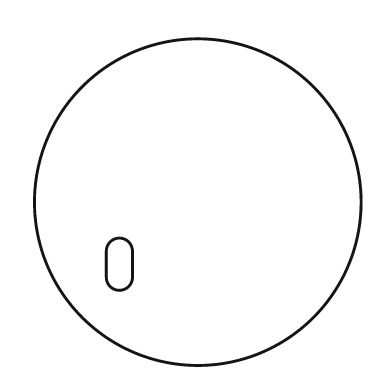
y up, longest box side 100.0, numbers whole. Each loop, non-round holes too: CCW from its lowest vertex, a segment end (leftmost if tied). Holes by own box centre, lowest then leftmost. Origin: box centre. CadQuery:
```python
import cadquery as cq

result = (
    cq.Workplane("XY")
    .moveTo(0.0, 0.0)
    .circle(50.0)
    .moveTo(-28.0, -23.0)
    .threePointArc((-24.0, -27.0), (-20.0, -23.0))
    .lineTo(-20.0, -15.0)
    .threePointArc((-24.0, -11.0), (-28.0, -15.0))
    .close()
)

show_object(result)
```